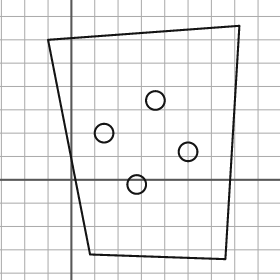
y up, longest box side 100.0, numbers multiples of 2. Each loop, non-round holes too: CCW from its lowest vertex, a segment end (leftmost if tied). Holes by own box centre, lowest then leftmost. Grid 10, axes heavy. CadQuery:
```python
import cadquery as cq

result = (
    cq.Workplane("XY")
    .moveTo(66.0, -34.0)
    .lineTo(72.0, 66.0)
    .lineTo(-10.0, 60.0)
    .lineTo(8.0, -32.0)
    .close()
    .moveTo(28.0, -2.0)
    .circle(4.0)
    .moveTo(50.0, 12.0)
    .circle(4.0)
    .moveTo(14.0, 20.0)
    .circle(4.0)
    .moveTo(36.0, 34.0)
    .circle(4.0)
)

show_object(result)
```